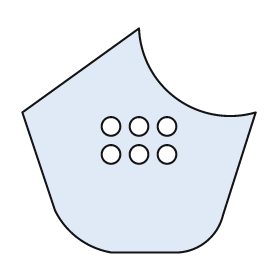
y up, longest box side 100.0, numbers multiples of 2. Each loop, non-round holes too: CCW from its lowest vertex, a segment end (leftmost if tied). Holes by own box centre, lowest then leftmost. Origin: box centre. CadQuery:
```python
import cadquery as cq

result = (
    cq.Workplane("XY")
    .moveTo(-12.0, -48.0)
    .lineTo(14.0, -48.0)
    .threePointArc((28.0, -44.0), (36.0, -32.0))
    .lineTo(50.0, 12.0)
    .threePointArc((16.0, 18.0), (0.0, 48.0))
    .lineTo(-50.0, 12.0)
    .lineTo(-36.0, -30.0)
    .threePointArc((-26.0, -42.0), (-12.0, -48.0))
    .close()
    .moveTo(-12.0, -6.0)
    .circle(4.0)
    .moveTo(0.0, -6.0)
    .circle(4.0)
    .moveTo(12.0, -6.0)
    .circle(4.0)
    .moveTo(-12.0, 6.0)
    .circle(4.0)
    .moveTo(0.0, 6.0)
    .circle(4.0)
    .moveTo(12.0, 6.0)
    .circle(4.0)
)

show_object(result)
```